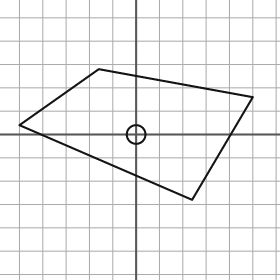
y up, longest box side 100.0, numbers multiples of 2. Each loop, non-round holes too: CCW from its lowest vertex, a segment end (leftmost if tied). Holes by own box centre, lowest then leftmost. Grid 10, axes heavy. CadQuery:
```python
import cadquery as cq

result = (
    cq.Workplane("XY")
    .moveTo(24.0, -28.0)
    .lineTo(50.0, 16.0)
    .lineTo(-16.0, 28.0)
    .lineTo(-50.0, 4.0)
    .close()
    .moveTo(0.0, 0.0)
    .circle(4.0)
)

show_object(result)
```